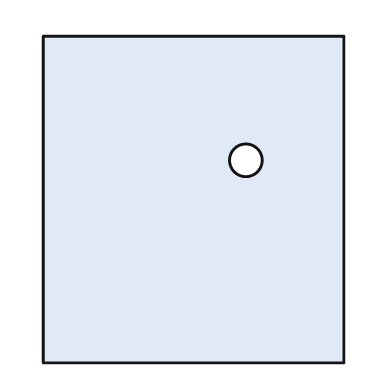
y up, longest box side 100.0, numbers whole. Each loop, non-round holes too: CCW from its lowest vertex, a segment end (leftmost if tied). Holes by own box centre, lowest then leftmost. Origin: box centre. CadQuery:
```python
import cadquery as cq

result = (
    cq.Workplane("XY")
    .moveTo(-46.0, -50.0)
    .lineTo(46.0, -50.0)
    .lineTo(46.0, 50.0)
    .lineTo(-46.0, 50.0)
    .close()
    .moveTo(16.0, 12.0)
    .circle(5.0)
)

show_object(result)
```